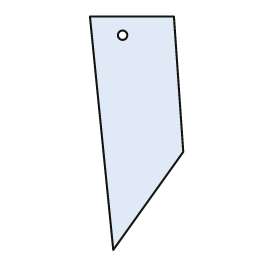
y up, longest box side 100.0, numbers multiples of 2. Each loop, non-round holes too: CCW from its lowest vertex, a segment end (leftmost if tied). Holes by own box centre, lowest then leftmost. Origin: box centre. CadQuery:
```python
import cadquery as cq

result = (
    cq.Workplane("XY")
    .moveTo(-10.0, -50.0)
    .lineTo(20.0, -8.0)
    .lineTo(16.0, 50.0)
    .lineTo(-20.0, 50.0)
    .close()
    .moveTo(-6.0, 42.0)
    .circle(2.0)
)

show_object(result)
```